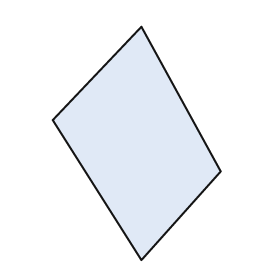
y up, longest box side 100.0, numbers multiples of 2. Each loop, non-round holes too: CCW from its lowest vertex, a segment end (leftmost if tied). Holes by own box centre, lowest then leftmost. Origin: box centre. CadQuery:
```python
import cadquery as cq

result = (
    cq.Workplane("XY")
    .moveTo(2.0, -50.0)
    .lineTo(36.0, -12.0)
    .lineTo(2.0, 50.0)
    .lineTo(-36.0, 10.0)
    .close()
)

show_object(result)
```